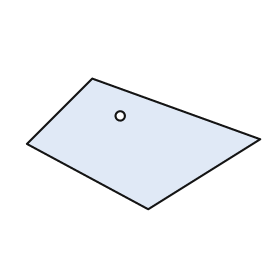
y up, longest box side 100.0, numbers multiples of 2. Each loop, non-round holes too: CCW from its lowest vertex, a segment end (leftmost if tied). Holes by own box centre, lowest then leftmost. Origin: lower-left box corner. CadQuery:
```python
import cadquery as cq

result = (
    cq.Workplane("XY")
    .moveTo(52.0, 0.0)
    .lineTo(100.0, 30.0)
    .lineTo(28.0, 56.0)
    .lineTo(0.0, 28.0)
    .close()
    .moveTo(40.0, 40.0)
    .circle(2.0)
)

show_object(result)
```